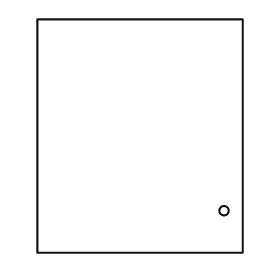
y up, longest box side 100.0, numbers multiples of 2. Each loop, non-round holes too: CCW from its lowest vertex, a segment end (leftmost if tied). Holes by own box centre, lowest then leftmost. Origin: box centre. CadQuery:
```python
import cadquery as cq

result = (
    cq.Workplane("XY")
    .moveTo(-44.0, -50.0)
    .lineTo(44.0, -50.0)
    .lineTo(44.0, 50.0)
    .lineTo(-44.0, 50.0)
    .close()
    .moveTo(36.0, -32.0)
    .circle(2.0)
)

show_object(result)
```